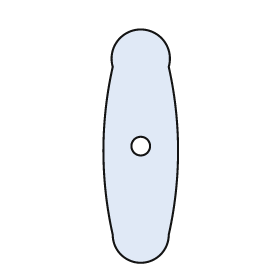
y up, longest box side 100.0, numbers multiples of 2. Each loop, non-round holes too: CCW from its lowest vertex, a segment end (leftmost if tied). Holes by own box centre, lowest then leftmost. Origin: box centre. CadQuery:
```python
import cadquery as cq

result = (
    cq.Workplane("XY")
    .moveTo(-12.0, -38.0)
    .threePointArc((0.0, -50.0), (12.0, -38.0))
    .threePointArc((16.0, -2.0), (12.0, 34.0))
    .threePointArc((0.0, 50.0), (-12.0, 34.0))
    .threePointArc((-16.0, -2.0), (-12.0, -38.0))
    .close()
    .moveTo(0.0, 0.0)
    .circle(4.0)
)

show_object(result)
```